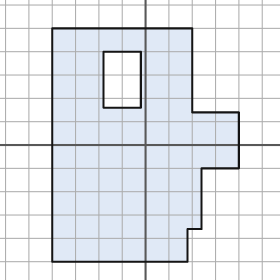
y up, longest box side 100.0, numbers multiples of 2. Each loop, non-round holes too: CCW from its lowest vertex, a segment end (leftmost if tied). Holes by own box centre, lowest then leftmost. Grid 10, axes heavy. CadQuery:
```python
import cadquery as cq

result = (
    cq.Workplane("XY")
    .moveTo(-40.0, -50.0)
    .lineTo(18.0, -50.0)
    .lineTo(18.0, -36.0)
    .lineTo(24.0, -36.0)
    .lineTo(24.0, -10.0)
    .lineTo(40.0, -10.0)
    .lineTo(40.0, 14.0)
    .lineTo(20.0, 14.0)
    .lineTo(20.0, 50.0)
    .lineTo(-40.0, 50.0)
    .close()
    .moveTo(-18.0, 16.0)
    .lineTo(-2.0, 16.0)
    .lineTo(-2.0, 40.0)
    .lineTo(-18.0, 40.0)
    .close()
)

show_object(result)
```